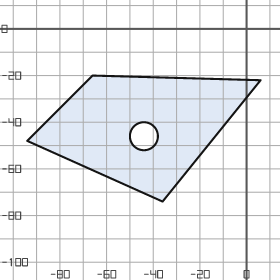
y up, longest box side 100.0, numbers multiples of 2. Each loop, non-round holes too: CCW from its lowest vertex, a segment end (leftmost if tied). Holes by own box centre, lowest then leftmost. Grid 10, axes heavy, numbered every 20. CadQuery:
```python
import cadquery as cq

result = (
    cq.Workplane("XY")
    .moveTo(-36.0, -74.0)
    .lineTo(6.0, -22.0)
    .lineTo(-66.0, -20.0)
    .lineTo(-94.0, -48.0)
    .close()
    .moveTo(-44.0, -46.0)
    .circle(6.0)
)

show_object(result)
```